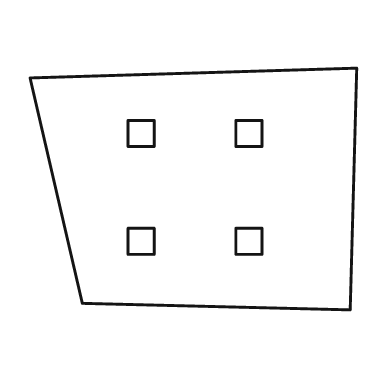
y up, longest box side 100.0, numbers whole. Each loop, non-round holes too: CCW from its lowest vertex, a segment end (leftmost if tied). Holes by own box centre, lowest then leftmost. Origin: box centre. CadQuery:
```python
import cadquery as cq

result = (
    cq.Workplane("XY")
    .moveTo(48.0, -37.0)
    .lineTo(50.0, 37.0)
    .lineTo(-50.0, 34.0)
    .lineTo(-34.0, -35.0)
    .close()
    .moveTo(-20.0, -20.0)
    .lineTo(-12.0, -20.0)
    .lineTo(-12.0, -12.0)
    .lineTo(-20.0, -12.0)
    .close()
    .moveTo(13.0, -20.0)
    .lineTo(21.0, -20.0)
    .lineTo(21.0, -12.0)
    .lineTo(13.0, -12.0)
    .close()
    .moveTo(-20.0, 13.0)
    .lineTo(-12.0, 13.0)
    .lineTo(-12.0, 21.0)
    .lineTo(-20.0, 21.0)
    .close()
    .moveTo(13.0, 13.0)
    .lineTo(21.0, 13.0)
    .lineTo(21.0, 21.0)
    .lineTo(13.0, 21.0)
    .close()
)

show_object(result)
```